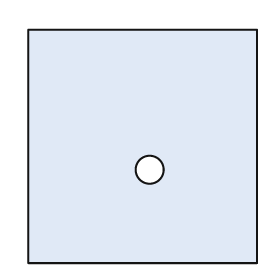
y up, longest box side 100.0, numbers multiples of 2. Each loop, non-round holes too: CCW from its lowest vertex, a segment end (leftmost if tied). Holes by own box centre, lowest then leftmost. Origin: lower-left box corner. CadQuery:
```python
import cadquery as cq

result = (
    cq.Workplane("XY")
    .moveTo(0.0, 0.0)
    .lineTo(98.0, 0.0)
    .lineTo(98.0, 100.0)
    .lineTo(0.0, 100.0)
    .close()
    .moveTo(52.0, 40.0)
    .circle(6.0)
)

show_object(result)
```